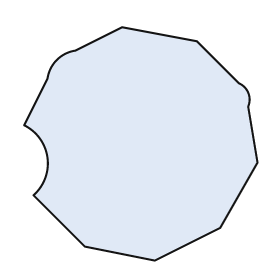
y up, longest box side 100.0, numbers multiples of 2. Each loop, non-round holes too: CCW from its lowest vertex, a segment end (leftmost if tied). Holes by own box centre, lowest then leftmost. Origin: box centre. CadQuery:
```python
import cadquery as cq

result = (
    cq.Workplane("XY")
    .moveTo(6.0, -50.0)
    .lineTo(34.0, -36.0)
    .lineTo(50.0, -8.0)
    .lineTo(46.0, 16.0)
    .threePointArc((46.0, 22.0), (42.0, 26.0))
    .lineTo(24.0, 44.0)
    .lineTo(-8.0, 50.0)
    .lineTo(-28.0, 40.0)
    .threePointArc((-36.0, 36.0), (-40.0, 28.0))
    .lineTo(-50.0, 8.0)
    .threePointArc((-40.0, -6.0), (-46.0, -22.0))
    .lineTo(-24.0, -44.0)
    .close()
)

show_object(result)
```